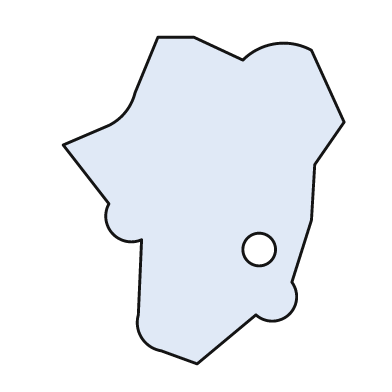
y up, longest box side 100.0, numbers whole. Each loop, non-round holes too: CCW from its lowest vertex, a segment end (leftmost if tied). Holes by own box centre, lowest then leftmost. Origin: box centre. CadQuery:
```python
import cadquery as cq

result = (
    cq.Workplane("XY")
    .moveTo(-2.0, -50.0)
    .lineTo(16.0, -35.0)
    .threePointArc((26.0, -35.0), (27.0, -25.0))
    .lineTo(33.0, -6.0)
    .lineTo(34.0, 11.0)
    .lineTo(43.0, 24.0)
    .lineTo(33.0, 46.0)
    .threePointArc((22.0, 48.0), (12.0, 43.0))
    .lineTo(-3.0, 50.0)
    .lineTo(-14.0, 50.0)
    .lineTo(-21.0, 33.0)
    .threePointArc((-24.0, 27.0), (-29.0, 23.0))
    .lineTo(-43.0, 17.0)
    .lineTo(-29.0, -1.0)
    .threePointArc((-28.0, -10.0), (-19.0, -12.0))
    .lineTo(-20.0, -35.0)
    .threePointArc((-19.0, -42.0), (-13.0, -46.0))
    .close()
    .moveTo(17.0, -15.0)
    .circle(5.0)
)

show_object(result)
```